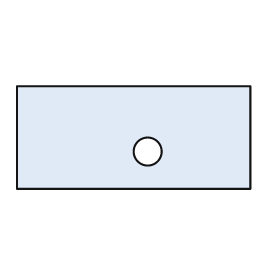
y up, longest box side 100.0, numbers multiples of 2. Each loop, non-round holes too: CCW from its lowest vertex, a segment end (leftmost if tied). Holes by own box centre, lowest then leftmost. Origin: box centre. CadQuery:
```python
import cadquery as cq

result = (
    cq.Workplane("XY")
    .moveTo(-50.0, -22.0)
    .lineTo(50.0, -22.0)
    .lineTo(50.0, 22.0)
    .lineTo(-50.0, 22.0)
    .close()
    .moveTo(6.0, -6.0)
    .circle(6.0)
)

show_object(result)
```